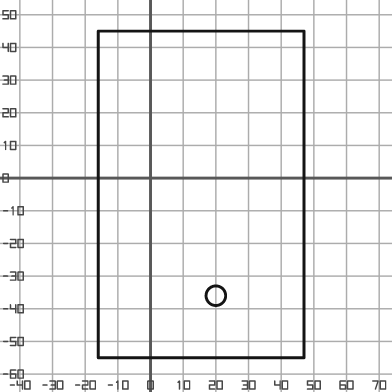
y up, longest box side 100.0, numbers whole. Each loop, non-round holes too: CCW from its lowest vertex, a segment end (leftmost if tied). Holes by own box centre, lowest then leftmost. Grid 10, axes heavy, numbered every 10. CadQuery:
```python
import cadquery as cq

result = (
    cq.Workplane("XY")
    .moveTo(-16.0, -55.0)
    .lineTo(47.0, -55.0)
    .lineTo(47.0, 45.0)
    .lineTo(-16.0, 45.0)
    .close()
    .moveTo(20.0, -36.0)
    .circle(3.0)
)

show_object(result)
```